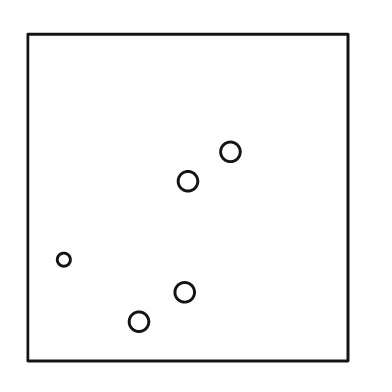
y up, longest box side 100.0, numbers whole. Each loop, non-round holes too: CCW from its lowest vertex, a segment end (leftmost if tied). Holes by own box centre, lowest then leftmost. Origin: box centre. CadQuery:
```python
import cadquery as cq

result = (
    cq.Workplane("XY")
    .moveTo(-49.0, -50.0)
    .lineTo(49.0, -50.0)
    .lineTo(49.0, 50.0)
    .lineTo(-49.0, 50.0)
    .close()
    .moveTo(-15.0, -38.0)
    .circle(3.0)
    .moveTo(-1.0, -29.0)
    .circle(3.0)
    .moveTo(-38.0, -19.0)
    .circle(2.0)
    .moveTo(0.0, 5.0)
    .circle(3.0)
    .moveTo(13.0, 14.0)
    .circle(3.0)
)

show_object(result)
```